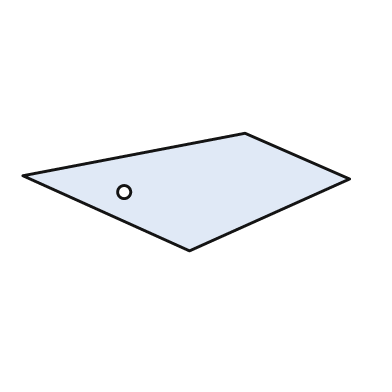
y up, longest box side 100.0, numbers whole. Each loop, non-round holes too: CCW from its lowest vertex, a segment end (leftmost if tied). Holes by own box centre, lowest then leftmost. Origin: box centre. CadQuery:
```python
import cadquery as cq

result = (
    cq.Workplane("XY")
    .moveTo(1.0, -18.0)
    .lineTo(50.0, 4.0)
    .lineTo(18.0, 18.0)
    .lineTo(-50.0, 5.0)
    .close()
    .moveTo(-19.0, 0.0)
    .circle(2.0)
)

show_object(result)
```